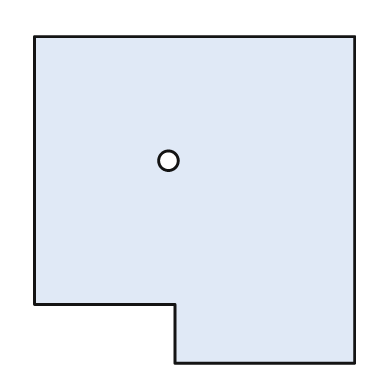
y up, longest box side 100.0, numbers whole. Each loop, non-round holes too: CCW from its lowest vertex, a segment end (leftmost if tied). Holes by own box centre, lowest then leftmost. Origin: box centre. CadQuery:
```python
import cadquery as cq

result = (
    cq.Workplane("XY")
    .moveTo(-6.0, -50.0)
    .lineTo(49.0, -50.0)
    .lineTo(49.0, 50.0)
    .lineTo(-49.0, 50.0)
    .lineTo(-49.0, -32.0)
    .lineTo(-6.0, -32.0)
    .close()
    .moveTo(-8.0, 12.0)
    .circle(3.0)
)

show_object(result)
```